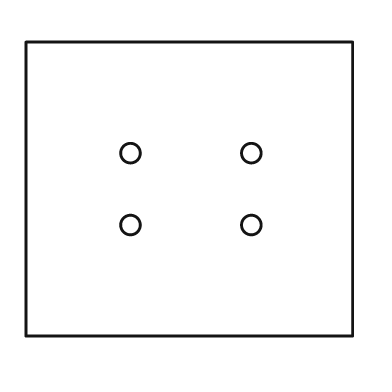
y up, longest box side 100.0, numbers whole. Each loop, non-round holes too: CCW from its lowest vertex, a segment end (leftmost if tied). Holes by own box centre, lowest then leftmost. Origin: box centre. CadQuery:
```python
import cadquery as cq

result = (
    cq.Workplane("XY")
    .moveTo(-50.0, -45.0)
    .lineTo(50.0, -45.0)
    .lineTo(50.0, 45.0)
    .lineTo(-50.0, 45.0)
    .close()
    .moveTo(-18.0, -11.0)
    .circle(3.0)
    .moveTo(19.0, -11.0)
    .circle(3.0)
    .moveTo(-18.0, 11.0)
    .circle(3.0)
    .moveTo(19.0, 11.0)
    .circle(3.0)
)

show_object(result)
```